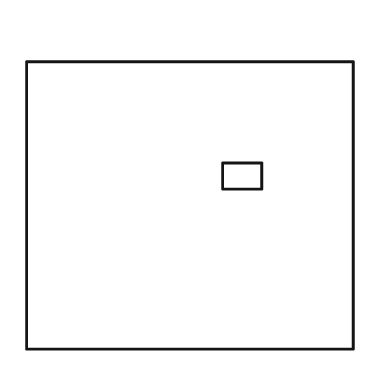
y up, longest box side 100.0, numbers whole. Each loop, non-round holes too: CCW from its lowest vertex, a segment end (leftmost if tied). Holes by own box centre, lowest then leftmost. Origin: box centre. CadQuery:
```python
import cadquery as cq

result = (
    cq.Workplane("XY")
    .moveTo(-50.0, -44.0)
    .lineTo(50.0, -44.0)
    .lineTo(50.0, 44.0)
    .lineTo(-50.0, 44.0)
    .close()
    .moveTo(10.0, 5.0)
    .lineTo(22.0, 5.0)
    .lineTo(22.0, 13.0)
    .lineTo(10.0, 13.0)
    .close()
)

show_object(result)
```